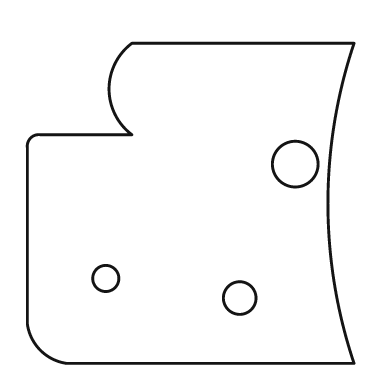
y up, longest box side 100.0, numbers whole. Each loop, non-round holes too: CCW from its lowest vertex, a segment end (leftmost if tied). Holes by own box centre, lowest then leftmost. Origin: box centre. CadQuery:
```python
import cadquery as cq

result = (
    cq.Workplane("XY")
    .moveTo(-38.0, -49.0)
    .lineTo(50.0, -49.0)
    .threePointArc((42.0, 0.0), (50.0, 49.0))
    .lineTo(-18.0, 49.0)
    .threePointArc((-25.0, 35.0), (-18.0, 21.0))
    .lineTo(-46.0, 21.0)
    .threePointArc((-49.0, 20.0), (-50.0, 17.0))
    .lineTo(-50.0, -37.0)
    .threePointArc((-46.0, -45.0), (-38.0, -49.0))
    .close()
    .moveTo(15.0, -29.0)
    .circle(5.0)
    .moveTo(-26.0, -23.0)
    .circle(4.0)
    .moveTo(32.0, 12.0)
    .circle(7.0)
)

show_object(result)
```